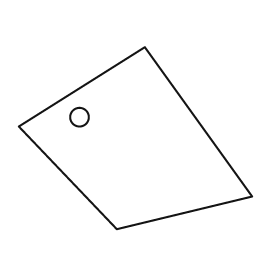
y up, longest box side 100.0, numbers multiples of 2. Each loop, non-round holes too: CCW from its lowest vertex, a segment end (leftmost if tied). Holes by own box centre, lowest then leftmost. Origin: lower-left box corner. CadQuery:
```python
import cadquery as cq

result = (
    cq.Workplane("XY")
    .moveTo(42.0, 0.0)
    .lineTo(100.0, 14.0)
    .lineTo(54.0, 78.0)
    .lineTo(0.0, 44.0)
    .close()
    .moveTo(26.0, 48.0)
    .circle(4.0)
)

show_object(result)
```